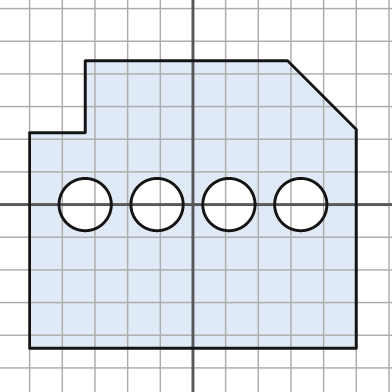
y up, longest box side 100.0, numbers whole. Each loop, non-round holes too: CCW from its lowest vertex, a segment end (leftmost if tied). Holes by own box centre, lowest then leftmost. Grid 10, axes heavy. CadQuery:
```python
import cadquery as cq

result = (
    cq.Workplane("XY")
    .moveTo(-50.0, -44.0)
    .lineTo(50.0, -44.0)
    .lineTo(50.0, 23.0)
    .lineTo(29.0, 44.0)
    .lineTo(-33.0, 44.0)
    .lineTo(-33.0, 22.0)
    .lineTo(-50.0, 22.0)
    .close()
    .moveTo(-33.0, 0.0)
    .circle(8.0)
    .moveTo(-11.0, 0.0)
    .circle(8.0)
    .moveTo(11.0, 0.0)
    .circle(8.0)
    .moveTo(33.0, 0.0)
    .circle(8.0)
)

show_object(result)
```